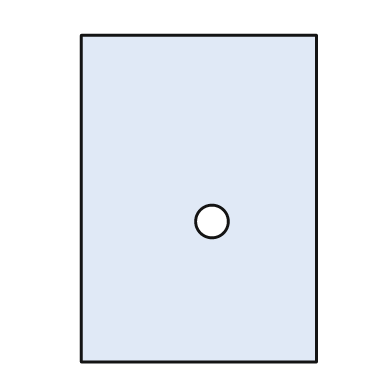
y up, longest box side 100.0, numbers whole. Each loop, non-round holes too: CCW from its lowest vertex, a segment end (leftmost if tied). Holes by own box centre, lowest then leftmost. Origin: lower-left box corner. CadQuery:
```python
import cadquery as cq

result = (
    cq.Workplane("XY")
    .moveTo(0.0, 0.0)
    .lineTo(72.0, 0.0)
    .lineTo(72.0, 100.0)
    .lineTo(0.0, 100.0)
    .close()
    .moveTo(40.0, 43.0)
    .circle(5.0)
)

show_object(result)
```